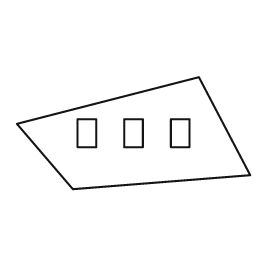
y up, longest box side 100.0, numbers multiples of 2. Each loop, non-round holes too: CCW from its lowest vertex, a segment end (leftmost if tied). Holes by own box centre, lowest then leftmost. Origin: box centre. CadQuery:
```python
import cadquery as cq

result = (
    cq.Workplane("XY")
    .moveTo(-26.0, -24.0)
    .lineTo(50.0, -18.0)
    .lineTo(28.0, 24.0)
    .lineTo(-50.0, 4.0)
    .close()
    .moveTo(-24.0, -6.0)
    .lineTo(-16.0, -6.0)
    .lineTo(-16.0, 6.0)
    .lineTo(-24.0, 6.0)
    .close()
    .moveTo(-4.0, -6.0)
    .lineTo(4.0, -6.0)
    .lineTo(4.0, 6.0)
    .lineTo(-4.0, 6.0)
    .close()
    .moveTo(16.0, -6.0)
    .lineTo(24.0, -6.0)
    .lineTo(24.0, 6.0)
    .lineTo(16.0, 6.0)
    .close()
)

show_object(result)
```